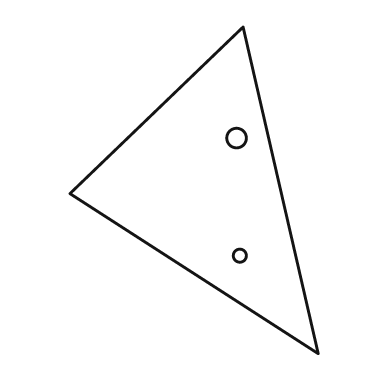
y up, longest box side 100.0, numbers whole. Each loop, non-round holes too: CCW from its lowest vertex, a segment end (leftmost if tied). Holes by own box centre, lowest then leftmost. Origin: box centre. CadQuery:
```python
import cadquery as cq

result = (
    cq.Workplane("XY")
    .moveTo(38.0, -50.0)
    .lineTo(15.0, 50.0)
    .lineTo(-38.0, -1.0)
    .close()
    .moveTo(14.0, -20.0)
    .circle(2.0)
    .moveTo(13.0, 16.0)
    .circle(3.0)
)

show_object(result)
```